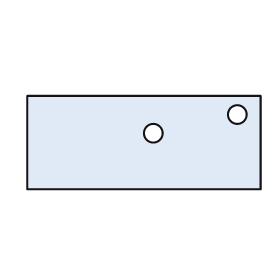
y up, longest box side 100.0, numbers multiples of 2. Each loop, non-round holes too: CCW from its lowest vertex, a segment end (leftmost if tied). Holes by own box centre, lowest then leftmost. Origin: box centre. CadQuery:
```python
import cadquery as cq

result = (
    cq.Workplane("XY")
    .moveTo(-50.0, -20.0)
    .lineTo(50.0, -20.0)
    .lineTo(50.0, 20.0)
    .lineTo(-50.0, 20.0)
    .close()
    .moveTo(4.0, 4.0)
    .circle(4.0)
    .moveTo(40.0, 12.0)
    .circle(4.0)
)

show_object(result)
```